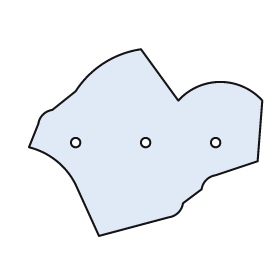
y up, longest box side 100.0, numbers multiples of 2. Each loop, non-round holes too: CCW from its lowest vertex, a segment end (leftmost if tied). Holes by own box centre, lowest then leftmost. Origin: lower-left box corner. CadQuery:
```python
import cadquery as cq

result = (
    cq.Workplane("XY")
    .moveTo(30.0, 0.0)
    .lineTo(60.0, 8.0)
    .threePointArc((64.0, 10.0), (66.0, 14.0))
    .lineTo(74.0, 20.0)
    .threePointArc((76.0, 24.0), (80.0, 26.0))
    .lineTo(98.0, 32.0)
    .lineTo(100.0, 58.0)
    .threePointArc((82.0, 66.0), (64.0, 58.0))
    .lineTo(48.0, 80.0)
    .threePointArc((32.0, 74.0), (20.0, 62.0))
    .lineTo(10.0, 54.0)
    .threePointArc((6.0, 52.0), (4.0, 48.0))
    .lineTo(0.0, 38.0)
    .threePointArc((12.0, 32.0), (20.0, 22.0))
    .close()
    .moveTo(20.0, 40.0)
    .circle(2.0)
    .moveTo(50.0, 40.0)
    .circle(2.0)
    .moveTo(80.0, 40.0)
    .circle(2.0)
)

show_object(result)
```